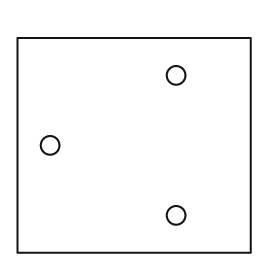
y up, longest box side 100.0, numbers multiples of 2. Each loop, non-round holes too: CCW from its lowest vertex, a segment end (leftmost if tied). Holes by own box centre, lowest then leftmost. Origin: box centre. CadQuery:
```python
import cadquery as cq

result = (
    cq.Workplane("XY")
    .moveTo(-50.0, -46.0)
    .lineTo(50.0, -46.0)
    .lineTo(50.0, 46.0)
    .lineTo(-50.0, 46.0)
    .close()
    .moveTo(18.0, -30.0)
    .circle(4.0)
    .moveTo(-36.0, 0.0)
    .circle(4.0)
    .moveTo(18.0, 30.0)
    .circle(4.0)
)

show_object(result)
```